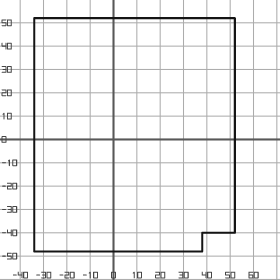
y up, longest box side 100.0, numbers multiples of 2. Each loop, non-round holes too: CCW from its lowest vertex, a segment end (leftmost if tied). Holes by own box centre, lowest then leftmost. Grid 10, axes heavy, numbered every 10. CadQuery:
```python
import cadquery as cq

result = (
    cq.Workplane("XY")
    .moveTo(-34.0, -48.0)
    .lineTo(38.0, -48.0)
    .lineTo(38.0, -40.0)
    .lineTo(52.0, -40.0)
    .lineTo(52.0, 52.0)
    .lineTo(-34.0, 52.0)
    .close()
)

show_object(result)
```